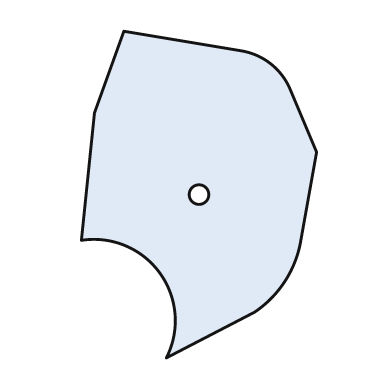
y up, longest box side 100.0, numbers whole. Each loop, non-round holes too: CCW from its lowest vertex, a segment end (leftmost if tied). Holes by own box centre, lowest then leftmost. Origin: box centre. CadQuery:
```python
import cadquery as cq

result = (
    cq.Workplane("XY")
    .moveTo(-10.0, -50.0)
    .lineTo(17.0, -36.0)
    .threePointArc((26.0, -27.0), (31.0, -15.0))
    .lineTo(36.0, 13.0)
    .lineTo(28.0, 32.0)
    .threePointArc((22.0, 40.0), (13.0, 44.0))
    .lineTo(-23.0, 50.0)
    .lineTo(-32.0, 25.0)
    .lineTo(-36.0, -14.0)
    .threePointArc((-12.0, -24.0), (-10.0, -50.0))
    .close()
    .moveTo(0.0, 0.0)
    .circle(3.0)
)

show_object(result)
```